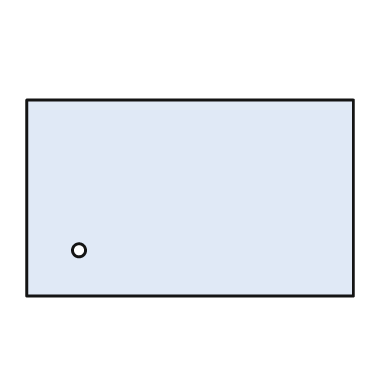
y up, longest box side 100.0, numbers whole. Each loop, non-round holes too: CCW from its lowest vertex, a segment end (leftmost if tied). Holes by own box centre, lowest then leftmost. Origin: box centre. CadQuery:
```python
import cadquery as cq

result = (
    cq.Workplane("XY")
    .moveTo(-50.0, -30.0)
    .lineTo(50.0, -30.0)
    .lineTo(50.0, 30.0)
    .lineTo(-50.0, 30.0)
    .close()
    .moveTo(-34.0, -16.0)
    .circle(2.0)
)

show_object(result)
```